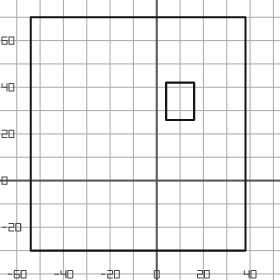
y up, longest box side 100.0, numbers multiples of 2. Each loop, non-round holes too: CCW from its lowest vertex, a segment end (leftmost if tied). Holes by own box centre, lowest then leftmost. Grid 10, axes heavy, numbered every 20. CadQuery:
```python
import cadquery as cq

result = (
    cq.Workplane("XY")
    .moveTo(-54.0, -30.0)
    .lineTo(38.0, -30.0)
    .lineTo(38.0, 70.0)
    .lineTo(-54.0, 70.0)
    .close()
    .moveTo(4.0, 26.0)
    .lineTo(16.0, 26.0)
    .lineTo(16.0, 42.0)
    .lineTo(4.0, 42.0)
    .close()
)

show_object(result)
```